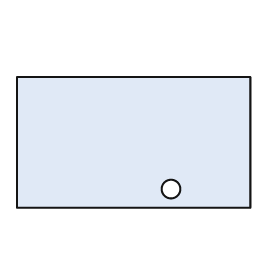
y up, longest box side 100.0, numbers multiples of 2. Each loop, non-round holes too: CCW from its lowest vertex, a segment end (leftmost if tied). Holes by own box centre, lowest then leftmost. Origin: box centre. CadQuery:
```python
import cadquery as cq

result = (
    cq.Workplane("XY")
    .moveTo(-50.0, -28.0)
    .lineTo(50.0, -28.0)
    .lineTo(50.0, 28.0)
    .lineTo(-50.0, 28.0)
    .close()
    .moveTo(16.0, -20.0)
    .circle(4.0)
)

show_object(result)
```